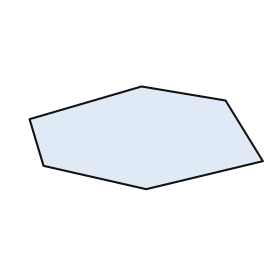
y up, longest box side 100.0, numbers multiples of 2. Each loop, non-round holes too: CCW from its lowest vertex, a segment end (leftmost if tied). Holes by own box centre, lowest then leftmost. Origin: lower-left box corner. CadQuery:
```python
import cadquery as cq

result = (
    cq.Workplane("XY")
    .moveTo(50.0, 0.0)
    .lineTo(100.0, 12.0)
    .lineTo(84.0, 38.0)
    .lineTo(48.0, 44.0)
    .lineTo(0.0, 30.0)
    .lineTo(6.0, 10.0)
    .close()
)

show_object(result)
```